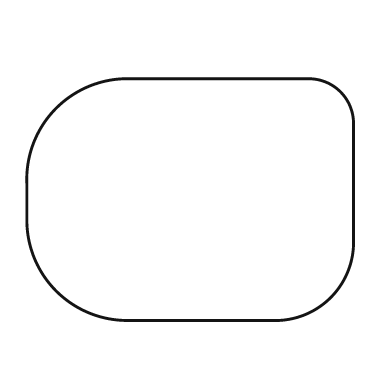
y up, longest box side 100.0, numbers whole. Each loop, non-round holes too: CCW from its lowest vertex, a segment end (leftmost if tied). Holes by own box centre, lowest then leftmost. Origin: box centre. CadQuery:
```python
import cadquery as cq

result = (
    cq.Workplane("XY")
    .moveTo(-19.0, -37.0)
    .lineTo(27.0, -37.0)
    .threePointArc((43.0, -30.0), (50.0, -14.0))
    .lineTo(50.0, 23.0)
    .threePointArc((46.0, 33.0), (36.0, 37.0))
    .lineTo(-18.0, 37.0)
    .threePointArc((-41.0, 28.0), (-50.0, 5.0))
    .lineTo(-50.0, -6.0)
    .threePointArc((-41.0, -28.0), (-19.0, -37.0))
    .close()
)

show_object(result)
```